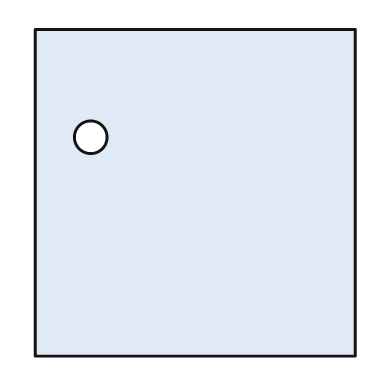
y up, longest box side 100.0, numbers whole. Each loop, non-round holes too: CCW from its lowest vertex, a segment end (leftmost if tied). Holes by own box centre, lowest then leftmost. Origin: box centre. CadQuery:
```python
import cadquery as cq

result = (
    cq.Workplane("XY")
    .moveTo(-49.0, -50.0)
    .lineTo(49.0, -50.0)
    .lineTo(49.0, 50.0)
    .lineTo(-49.0, 50.0)
    .close()
    .moveTo(-32.0, 17.0)
    .circle(5.0)
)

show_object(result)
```